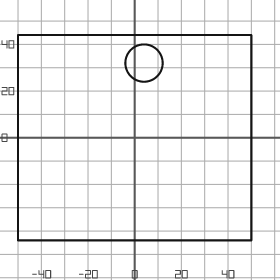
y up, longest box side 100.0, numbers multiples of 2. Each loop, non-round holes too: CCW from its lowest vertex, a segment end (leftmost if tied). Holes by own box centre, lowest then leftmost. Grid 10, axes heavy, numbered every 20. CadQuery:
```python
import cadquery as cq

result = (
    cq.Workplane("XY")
    .moveTo(-50.0, -44.0)
    .lineTo(50.0, -44.0)
    .lineTo(50.0, 44.0)
    .lineTo(-50.0, 44.0)
    .close()
    .moveTo(4.0, 32.0)
    .circle(8.0)
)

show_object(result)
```